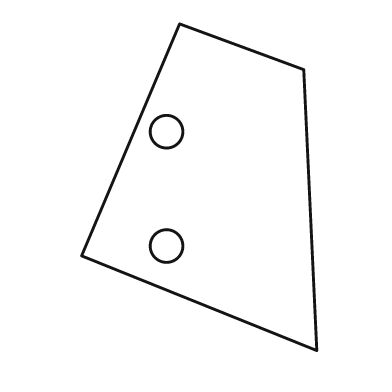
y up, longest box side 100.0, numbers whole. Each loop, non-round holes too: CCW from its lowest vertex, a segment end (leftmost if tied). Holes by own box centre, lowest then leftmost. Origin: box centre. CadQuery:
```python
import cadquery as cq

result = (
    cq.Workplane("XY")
    .moveTo(36.0, -50.0)
    .lineTo(32.0, 36.0)
    .lineTo(-6.0, 50.0)
    .lineTo(-36.0, -21.0)
    .close()
    .moveTo(-10.0, -18.0)
    .circle(5.0)
    .moveTo(-10.0, 17.0)
    .circle(5.0)
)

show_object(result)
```